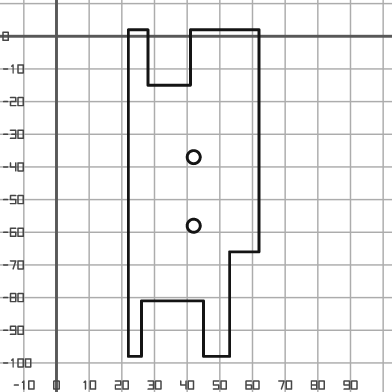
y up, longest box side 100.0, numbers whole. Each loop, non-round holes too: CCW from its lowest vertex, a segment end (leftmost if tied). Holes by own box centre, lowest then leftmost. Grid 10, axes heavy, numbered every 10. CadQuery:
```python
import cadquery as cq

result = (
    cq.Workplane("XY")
    .moveTo(22.0, -98.0)
    .lineTo(26.0, -98.0)
    .lineTo(26.0, -81.0)
    .lineTo(45.0, -81.0)
    .lineTo(45.0, -98.0)
    .lineTo(53.0, -98.0)
    .lineTo(53.0, -66.0)
    .lineTo(62.0, -66.0)
    .lineTo(62.0, 2.0)
    .lineTo(41.0, 2.0)
    .lineTo(41.0, -15.0)
    .lineTo(28.0, -15.0)
    .lineTo(28.0, 2.0)
    .lineTo(22.0, 2.0)
    .close()
    .moveTo(42.0, -58.0)
    .circle(2.0)
    .moveTo(42.0, -37.0)
    .circle(2.0)
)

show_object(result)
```